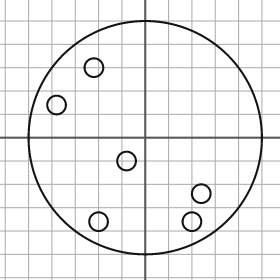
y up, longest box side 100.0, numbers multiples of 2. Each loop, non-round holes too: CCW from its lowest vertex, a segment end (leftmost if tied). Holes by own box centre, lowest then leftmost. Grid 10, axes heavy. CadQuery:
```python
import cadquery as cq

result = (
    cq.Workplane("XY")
    .moveTo(0.0, 0.0)
    .circle(50.0)
    .moveTo(-20.0, -36.0)
    .circle(4.0)
    .moveTo(20.0, -36.0)
    .circle(4.0)
    .moveTo(24.0, -24.0)
    .circle(4.0)
    .moveTo(-8.0, -10.0)
    .circle(4.0)
    .moveTo(-38.0, 14.0)
    .circle(4.0)
    .moveTo(-22.0, 30.0)
    .circle(4.0)
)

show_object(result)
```